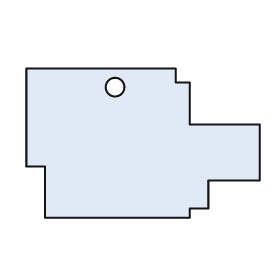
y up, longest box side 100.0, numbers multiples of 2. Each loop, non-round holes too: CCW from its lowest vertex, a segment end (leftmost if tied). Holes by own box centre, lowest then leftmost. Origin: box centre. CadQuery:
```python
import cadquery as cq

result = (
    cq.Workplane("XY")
    .moveTo(-42.0, -32.0)
    .lineTo(20.0, -32.0)
    .lineTo(20.0, -28.0)
    .lineTo(28.0, -28.0)
    .lineTo(28.0, -16.0)
    .lineTo(50.0, -16.0)
    .lineTo(50.0, 8.0)
    .lineTo(20.0, 8.0)
    .lineTo(20.0, 26.0)
    .lineTo(14.0, 26.0)
    .lineTo(14.0, 32.0)
    .lineTo(-50.0, 32.0)
    .lineTo(-50.0, -10.0)
    .lineTo(-42.0, -10.0)
    .close()
    .moveTo(-12.0, 24.0)
    .circle(4.0)
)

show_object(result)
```